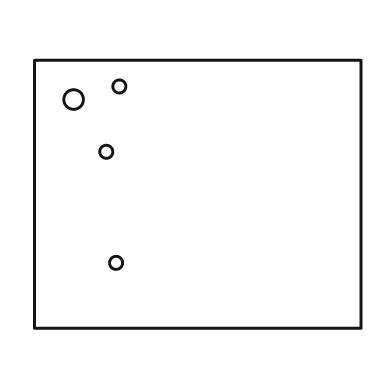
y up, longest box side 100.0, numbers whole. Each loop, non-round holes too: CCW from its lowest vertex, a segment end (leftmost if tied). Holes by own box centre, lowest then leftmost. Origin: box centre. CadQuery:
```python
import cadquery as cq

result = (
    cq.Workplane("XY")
    .moveTo(-50.0, -41.0)
    .lineTo(50.0, -41.0)
    .lineTo(50.0, 41.0)
    .lineTo(-50.0, 41.0)
    .close()
    .moveTo(-25.0, -21.0)
    .circle(2.0)
    .moveTo(-28.0, 13.0)
    .circle(2.0)
    .moveTo(-38.0, 29.0)
    .circle(3.0)
    .moveTo(-24.0, 33.0)
    .circle(2.0)
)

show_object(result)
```